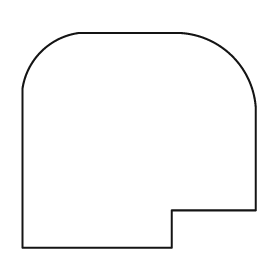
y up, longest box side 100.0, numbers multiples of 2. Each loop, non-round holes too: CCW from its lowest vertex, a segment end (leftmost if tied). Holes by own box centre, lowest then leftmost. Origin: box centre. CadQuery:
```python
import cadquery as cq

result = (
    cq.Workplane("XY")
    .moveTo(-50.0, -46.0)
    .lineTo(14.0, -46.0)
    .lineTo(14.0, -30.0)
    .lineTo(50.0, -30.0)
    .lineTo(50.0, 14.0)
    .threePointArc((40.0, 36.0), (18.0, 46.0))
    .lineTo(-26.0, 46.0)
    .threePointArc((-42.0, 38.0), (-50.0, 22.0))
    .close()
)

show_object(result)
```